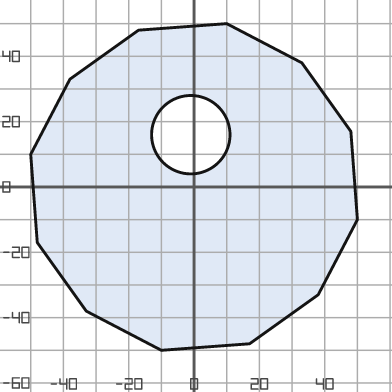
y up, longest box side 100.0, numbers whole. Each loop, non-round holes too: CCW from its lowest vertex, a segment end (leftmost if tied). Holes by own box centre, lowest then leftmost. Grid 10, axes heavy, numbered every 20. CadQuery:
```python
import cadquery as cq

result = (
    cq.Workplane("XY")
    .moveTo(-10.0, -50.0)
    .lineTo(17.0, -48.0)
    .lineTo(38.0, -33.0)
    .lineTo(50.0, -10.0)
    .lineTo(48.0, 17.0)
    .lineTo(33.0, 38.0)
    .lineTo(10.0, 50.0)
    .lineTo(-17.0, 48.0)
    .lineTo(-38.0, 33.0)
    .lineTo(-50.0, 10.0)
    .lineTo(-48.0, -17.0)
    .lineTo(-33.0, -38.0)
    .close()
    .moveTo(-1.0, 16.0)
    .circle(12.0)
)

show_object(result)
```